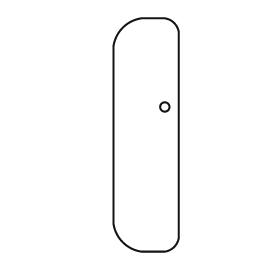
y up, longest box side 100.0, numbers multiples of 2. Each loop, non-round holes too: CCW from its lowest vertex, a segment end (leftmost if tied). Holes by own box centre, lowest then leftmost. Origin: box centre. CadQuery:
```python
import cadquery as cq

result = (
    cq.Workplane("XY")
    .moveTo(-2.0, -50.0)
    .lineTo(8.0, -50.0)
    .threePointArc((12.0, -48.0), (14.0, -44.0))
    .lineTo(14.0, 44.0)
    .threePointArc((12.0, 48.0), (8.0, 50.0))
    .lineTo(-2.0, 50.0)
    .threePointArc((-10.0, 46.0), (-14.0, 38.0))
    .lineTo(-14.0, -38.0)
    .threePointArc((-10.0, -46.0), (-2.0, -50.0))
    .close()
    .moveTo(8.0, 12.0)
    .circle(2.0)
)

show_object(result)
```